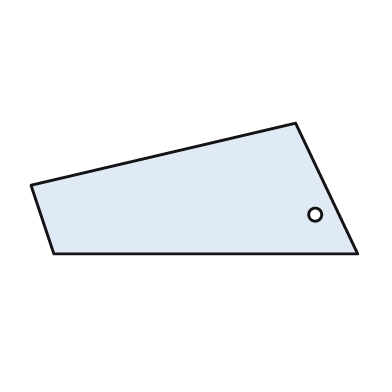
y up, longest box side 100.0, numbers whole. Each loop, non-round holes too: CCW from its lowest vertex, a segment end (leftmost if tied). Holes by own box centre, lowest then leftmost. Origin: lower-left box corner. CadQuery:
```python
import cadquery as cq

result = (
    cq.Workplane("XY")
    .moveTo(7.0, 0.0)
    .lineTo(100.0, 0.0)
    .lineTo(81.0, 40.0)
    .lineTo(0.0, 21.0)
    .close()
    .moveTo(87.0, 12.0)
    .circle(2.0)
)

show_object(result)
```